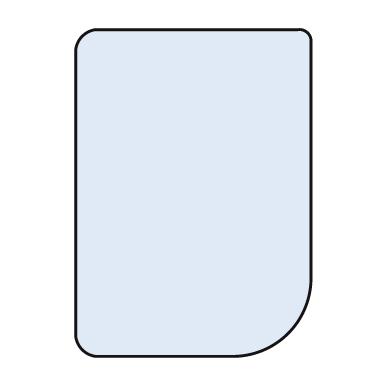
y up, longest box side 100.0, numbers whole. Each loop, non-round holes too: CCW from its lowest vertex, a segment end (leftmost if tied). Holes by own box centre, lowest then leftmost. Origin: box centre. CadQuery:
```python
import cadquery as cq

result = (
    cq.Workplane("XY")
    .moveTo(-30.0, -50.0)
    .lineTo(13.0, -50.0)
    .threePointArc((29.0, -43.0), (36.0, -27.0))
    .lineTo(36.0, 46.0)
    .threePointArc((35.0, 49.0), (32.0, 50.0))
    .lineTo(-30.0, 50.0)
    .threePointArc((-34.0, 48.0), (-36.0, 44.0))
    .lineTo(-36.0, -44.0)
    .threePointArc((-34.0, -48.0), (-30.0, -50.0))
    .close()
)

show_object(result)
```